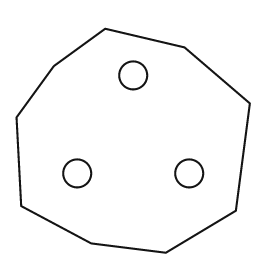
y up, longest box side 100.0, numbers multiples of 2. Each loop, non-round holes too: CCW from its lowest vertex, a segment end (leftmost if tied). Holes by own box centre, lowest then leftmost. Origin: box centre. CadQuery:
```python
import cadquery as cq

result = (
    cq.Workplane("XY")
    .moveTo(14.0, -48.0)
    .lineTo(44.0, -30.0)
    .lineTo(50.0, 16.0)
    .lineTo(22.0, 40.0)
    .lineTo(-12.0, 48.0)
    .lineTo(-34.0, 32.0)
    .lineTo(-50.0, 10.0)
    .lineTo(-48.0, -28.0)
    .lineTo(-18.0, -44.0)
    .close()
    .moveTo(-24.0, -14.0)
    .circle(6.0)
    .moveTo(24.0, -14.0)
    .circle(6.0)
    .moveTo(0.0, 28.0)
    .circle(6.0)
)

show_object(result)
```